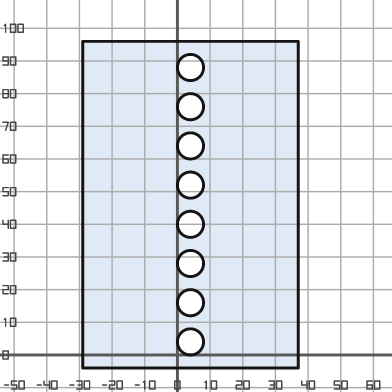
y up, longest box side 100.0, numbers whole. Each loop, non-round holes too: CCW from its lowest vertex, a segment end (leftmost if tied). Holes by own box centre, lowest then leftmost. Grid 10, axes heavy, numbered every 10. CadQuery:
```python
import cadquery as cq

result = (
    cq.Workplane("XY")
    .moveTo(-29.0, -4.0)
    .lineTo(37.0, -4.0)
    .lineTo(37.0, 96.0)
    .lineTo(-29.0, 96.0)
    .close()
    .moveTo(4.0, 4.0)
    .circle(4.0)
    .moveTo(4.0, 16.0)
    .circle(4.0)
    .moveTo(4.0, 28.0)
    .circle(4.0)
    .moveTo(4.0, 40.0)
    .circle(4.0)
    .moveTo(4.0, 52.0)
    .circle(4.0)
    .moveTo(4.0, 64.0)
    .circle(4.0)
    .moveTo(4.0, 76.0)
    .circle(4.0)
    .moveTo(4.0, 88.0)
    .circle(4.0)
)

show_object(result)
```